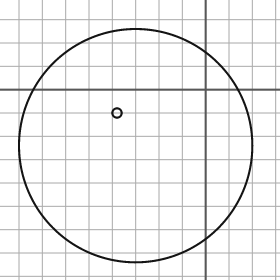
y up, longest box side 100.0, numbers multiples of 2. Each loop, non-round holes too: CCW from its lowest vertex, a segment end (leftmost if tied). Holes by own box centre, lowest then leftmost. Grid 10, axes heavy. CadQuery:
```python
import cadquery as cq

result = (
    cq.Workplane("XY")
    .moveTo(-30.0, -24.0)
    .circle(50.0)
    .moveTo(-38.0, -10.0)
    .circle(2.0)
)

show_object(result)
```